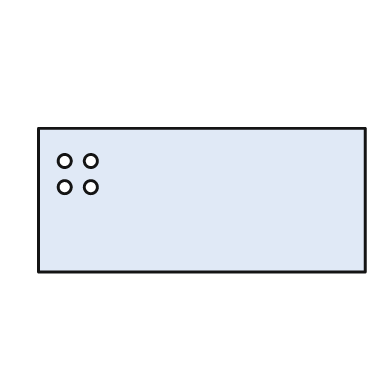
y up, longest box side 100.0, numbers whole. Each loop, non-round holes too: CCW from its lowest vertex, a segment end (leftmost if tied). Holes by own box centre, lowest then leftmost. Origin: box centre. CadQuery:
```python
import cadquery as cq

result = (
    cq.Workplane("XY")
    .moveTo(-50.0, -22.0)
    .lineTo(50.0, -22.0)
    .lineTo(50.0, 22.0)
    .lineTo(-50.0, 22.0)
    .close()
    .moveTo(-42.0, 4.0)
    .circle(2.0)
    .moveTo(-34.0, 4.0)
    .circle(2.0)
    .moveTo(-42.0, 12.0)
    .circle(2.0)
    .moveTo(-34.0, 12.0)
    .circle(2.0)
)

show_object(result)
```